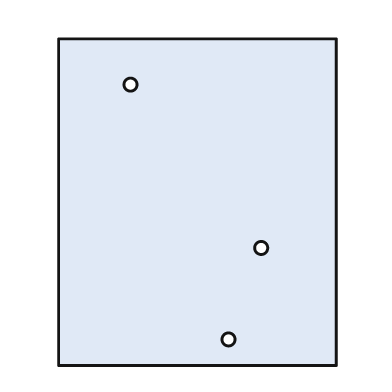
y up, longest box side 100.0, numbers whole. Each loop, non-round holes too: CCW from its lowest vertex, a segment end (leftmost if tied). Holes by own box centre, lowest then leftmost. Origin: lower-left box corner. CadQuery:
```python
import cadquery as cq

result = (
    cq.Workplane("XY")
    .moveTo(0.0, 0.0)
    .lineTo(85.0, 0.0)
    .lineTo(85.0, 100.0)
    .lineTo(0.0, 100.0)
    .close()
    .moveTo(52.0, 8.0)
    .circle(2.0)
    .moveTo(62.0, 36.0)
    .circle(2.0)
    .moveTo(22.0, 86.0)
    .circle(2.0)
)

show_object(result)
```